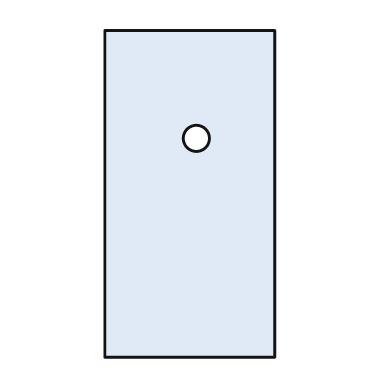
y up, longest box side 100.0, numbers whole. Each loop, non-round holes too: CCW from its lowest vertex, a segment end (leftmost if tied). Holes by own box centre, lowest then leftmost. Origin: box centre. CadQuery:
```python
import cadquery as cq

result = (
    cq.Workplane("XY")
    .moveTo(-26.0, -50.0)
    .lineTo(26.0, -50.0)
    .lineTo(26.0, 50.0)
    .lineTo(-26.0, 50.0)
    .close()
    .moveTo(2.0, 17.0)
    .circle(4.0)
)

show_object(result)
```